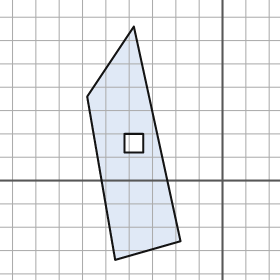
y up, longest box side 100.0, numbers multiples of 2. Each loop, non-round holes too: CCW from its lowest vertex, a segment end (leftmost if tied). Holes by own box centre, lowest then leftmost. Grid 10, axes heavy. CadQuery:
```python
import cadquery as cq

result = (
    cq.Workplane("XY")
    .moveTo(-46.0, -34.0)
    .lineTo(-18.0, -26.0)
    .lineTo(-38.0, 66.0)
    .lineTo(-58.0, 36.0)
    .close()
    .moveTo(-42.0, 12.0)
    .lineTo(-34.0, 12.0)
    .lineTo(-34.0, 20.0)
    .lineTo(-42.0, 20.0)
    .close()
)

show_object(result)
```